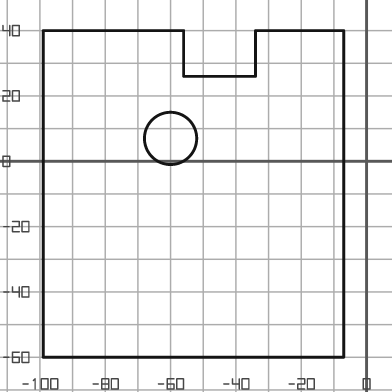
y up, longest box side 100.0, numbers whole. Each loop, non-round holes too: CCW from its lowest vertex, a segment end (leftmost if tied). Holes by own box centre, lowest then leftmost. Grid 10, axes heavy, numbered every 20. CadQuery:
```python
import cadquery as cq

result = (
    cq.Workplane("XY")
    .moveTo(-99.0, -60.0)
    .lineTo(-7.0, -60.0)
    .lineTo(-7.0, 40.0)
    .lineTo(-34.0, 40.0)
    .lineTo(-34.0, 26.0)
    .lineTo(-56.0, 26.0)
    .lineTo(-56.0, 40.0)
    .lineTo(-99.0, 40.0)
    .close()
    .moveTo(-60.0, 7.0)
    .circle(8.0)
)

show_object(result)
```